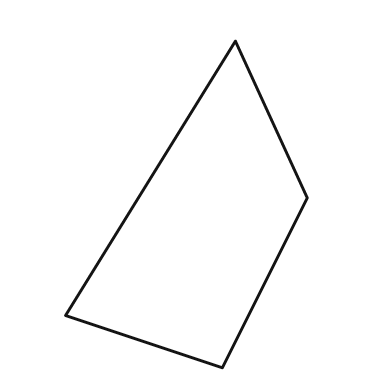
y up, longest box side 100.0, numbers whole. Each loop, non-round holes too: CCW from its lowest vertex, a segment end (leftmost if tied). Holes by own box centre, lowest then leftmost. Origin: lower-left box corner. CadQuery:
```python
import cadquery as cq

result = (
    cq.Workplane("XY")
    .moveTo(48.0, 0.0)
    .lineTo(74.0, 52.0)
    .lineTo(52.0, 100.0)
    .lineTo(0.0, 16.0)
    .close()
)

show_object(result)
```